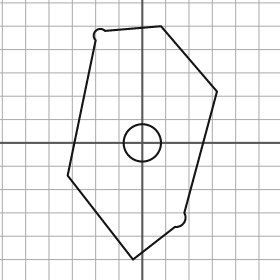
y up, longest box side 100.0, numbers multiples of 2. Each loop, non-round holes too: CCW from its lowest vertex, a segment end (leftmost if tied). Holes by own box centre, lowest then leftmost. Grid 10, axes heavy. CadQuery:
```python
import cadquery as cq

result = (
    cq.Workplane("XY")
    .moveTo(-4.0, -50.0)
    .lineTo(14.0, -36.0)
    .threePointArc((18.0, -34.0), (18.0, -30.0))
    .lineTo(32.0, 22.0)
    .lineTo(8.0, 50.0)
    .lineTo(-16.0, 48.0)
    .threePointArc((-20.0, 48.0), (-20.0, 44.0))
    .lineTo(-32.0, -14.0)
    .close()
    .moveTo(0.0, 0.0)
    .circle(8.0)
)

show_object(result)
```